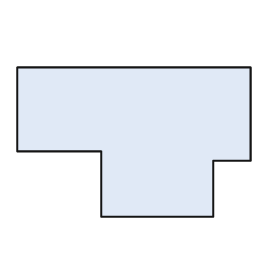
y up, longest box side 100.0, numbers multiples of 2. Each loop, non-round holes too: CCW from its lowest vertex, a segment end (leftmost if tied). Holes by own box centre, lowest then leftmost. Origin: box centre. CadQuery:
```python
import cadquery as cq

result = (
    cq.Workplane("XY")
    .moveTo(-14.0, -32.0)
    .lineTo(34.0, -32.0)
    .lineTo(34.0, -8.0)
    .lineTo(50.0, -8.0)
    .lineTo(50.0, 32.0)
    .lineTo(-50.0, 32.0)
    .lineTo(-50.0, -4.0)
    .lineTo(-14.0, -4.0)
    .close()
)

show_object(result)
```